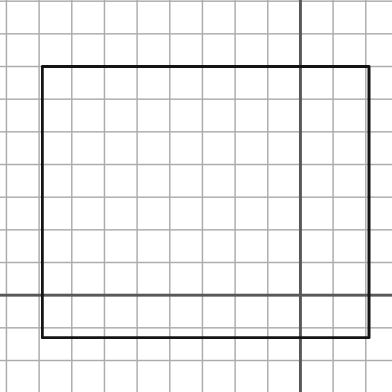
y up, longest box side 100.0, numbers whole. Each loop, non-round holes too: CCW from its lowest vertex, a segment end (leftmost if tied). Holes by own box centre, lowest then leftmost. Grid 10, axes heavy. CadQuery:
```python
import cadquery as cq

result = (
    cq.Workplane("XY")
    .moveTo(-79.0, -13.0)
    .lineTo(21.0, -13.0)
    .lineTo(21.0, 70.0)
    .lineTo(-79.0, 70.0)
    .close()
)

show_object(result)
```